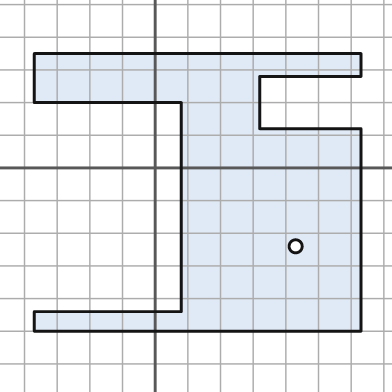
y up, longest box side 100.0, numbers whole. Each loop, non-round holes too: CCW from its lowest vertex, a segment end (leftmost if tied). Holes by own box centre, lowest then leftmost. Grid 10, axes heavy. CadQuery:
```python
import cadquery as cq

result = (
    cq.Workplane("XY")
    .moveTo(-37.0, -50.0)
    .lineTo(63.0, -50.0)
    .lineTo(63.0, 12.0)
    .lineTo(32.0, 12.0)
    .lineTo(32.0, 28.0)
    .lineTo(63.0, 28.0)
    .lineTo(63.0, 35.0)
    .lineTo(-37.0, 35.0)
    .lineTo(-37.0, 20.0)
    .lineTo(8.0, 20.0)
    .lineTo(8.0, -44.0)
    .lineTo(-37.0, -44.0)
    .close()
    .moveTo(43.0, -24.0)
    .circle(2.0)
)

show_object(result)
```